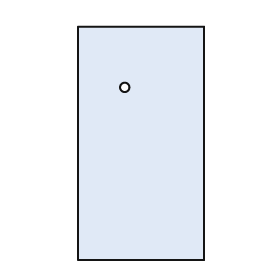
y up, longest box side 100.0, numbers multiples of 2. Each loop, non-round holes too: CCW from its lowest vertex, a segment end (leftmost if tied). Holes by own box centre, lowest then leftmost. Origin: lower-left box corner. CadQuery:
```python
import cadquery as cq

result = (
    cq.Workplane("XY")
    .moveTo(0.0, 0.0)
    .lineTo(54.0, 0.0)
    .lineTo(54.0, 100.0)
    .lineTo(0.0, 100.0)
    .close()
    .moveTo(20.0, 74.0)
    .circle(2.0)
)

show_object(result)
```